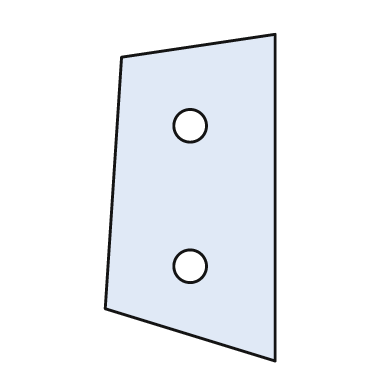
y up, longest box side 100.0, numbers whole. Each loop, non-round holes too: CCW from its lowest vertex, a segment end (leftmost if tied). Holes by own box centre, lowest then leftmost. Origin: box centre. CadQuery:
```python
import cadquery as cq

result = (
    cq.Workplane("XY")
    .moveTo(26.0, -50.0)
    .lineTo(26.0, 50.0)
    .lineTo(-21.0, 43.0)
    .lineTo(-26.0, -34.0)
    .close()
    .moveTo(0.0, -21.0)
    .circle(5.0)
    .moveTo(0.0, 22.0)
    .circle(5.0)
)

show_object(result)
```